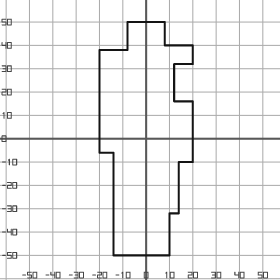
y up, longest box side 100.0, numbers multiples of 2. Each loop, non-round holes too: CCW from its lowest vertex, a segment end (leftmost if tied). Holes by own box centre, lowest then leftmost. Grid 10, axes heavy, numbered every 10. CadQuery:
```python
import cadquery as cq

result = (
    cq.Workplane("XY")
    .moveTo(-14.0, -50.0)
    .lineTo(10.0, -50.0)
    .lineTo(10.0, -32.0)
    .lineTo(14.0, -32.0)
    .lineTo(14.0, -10.0)
    .lineTo(20.0, -10.0)
    .lineTo(20.0, 16.0)
    .lineTo(12.0, 16.0)
    .lineTo(12.0, 32.0)
    .lineTo(20.0, 32.0)
    .lineTo(20.0, 40.0)
    .lineTo(8.0, 40.0)
    .lineTo(8.0, 50.0)
    .lineTo(-8.0, 50.0)
    .lineTo(-8.0, 38.0)
    .lineTo(-20.0, 38.0)
    .lineTo(-20.0, -6.0)
    .lineTo(-14.0, -6.0)
    .close()
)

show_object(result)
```